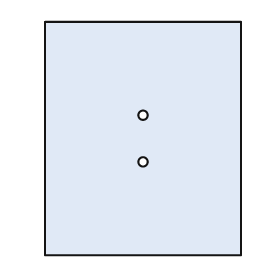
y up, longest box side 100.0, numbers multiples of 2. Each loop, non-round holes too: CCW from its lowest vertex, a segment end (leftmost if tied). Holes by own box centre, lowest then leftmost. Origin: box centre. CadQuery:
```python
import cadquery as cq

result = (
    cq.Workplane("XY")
    .moveTo(-42.0, -50.0)
    .lineTo(42.0, -50.0)
    .lineTo(42.0, 50.0)
    .lineTo(-42.0, 50.0)
    .close()
    .moveTo(0.0, -10.0)
    .circle(2.0)
    .moveTo(0.0, 10.0)
    .circle(2.0)
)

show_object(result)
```